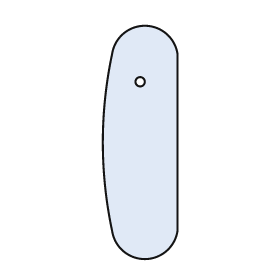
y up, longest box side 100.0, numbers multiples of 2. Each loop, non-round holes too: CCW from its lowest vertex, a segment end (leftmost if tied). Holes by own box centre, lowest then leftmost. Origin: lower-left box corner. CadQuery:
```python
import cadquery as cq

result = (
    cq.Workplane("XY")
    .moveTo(4.0, 12.0)
    .threePointArc((18.0, 0.0), (32.0, 12.0))
    .lineTo(32.0, 88.0)
    .threePointArc((18.0, 100.0), (4.0, 88.0))
    .threePointArc((0.0, 50.0), (4.0, 12.0))
    .close()
    .moveTo(16.0, 76.0)
    .circle(2.0)
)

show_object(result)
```